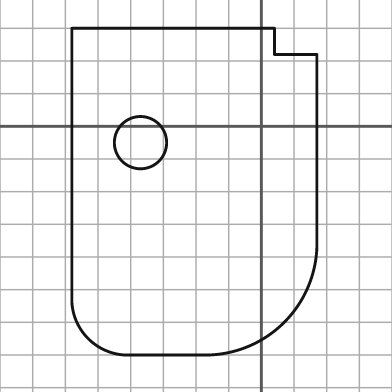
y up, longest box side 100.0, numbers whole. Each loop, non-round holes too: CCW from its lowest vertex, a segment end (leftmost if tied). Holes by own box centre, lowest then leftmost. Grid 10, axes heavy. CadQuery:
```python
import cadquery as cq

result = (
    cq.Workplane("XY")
    .moveTo(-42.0, -70.0)
    .lineTo(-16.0, -70.0)
    .threePointArc((7.0, -60.0), (17.0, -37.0))
    .lineTo(17.0, 22.0)
    .lineTo(4.0, 22.0)
    .lineTo(4.0, 30.0)
    .lineTo(-58.0, 30.0)
    .lineTo(-58.0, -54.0)
    .threePointArc((-53.0, -65.0), (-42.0, -70.0))
    .close()
    .moveTo(-37.0, -5.0)
    .circle(8.0)
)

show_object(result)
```